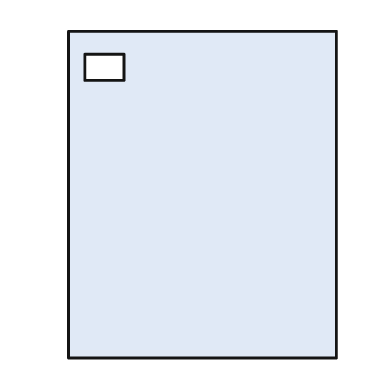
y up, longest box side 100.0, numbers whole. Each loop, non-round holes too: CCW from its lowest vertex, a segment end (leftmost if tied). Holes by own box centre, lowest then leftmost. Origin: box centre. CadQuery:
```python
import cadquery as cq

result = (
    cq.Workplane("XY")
    .moveTo(-41.0, -50.0)
    .lineTo(41.0, -50.0)
    .lineTo(41.0, 50.0)
    .lineTo(-41.0, 50.0)
    .close()
    .moveTo(-36.0, 35.0)
    .lineTo(-24.0, 35.0)
    .lineTo(-24.0, 43.0)
    .lineTo(-36.0, 43.0)
    .close()
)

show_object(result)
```